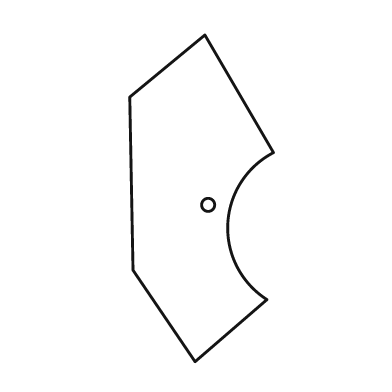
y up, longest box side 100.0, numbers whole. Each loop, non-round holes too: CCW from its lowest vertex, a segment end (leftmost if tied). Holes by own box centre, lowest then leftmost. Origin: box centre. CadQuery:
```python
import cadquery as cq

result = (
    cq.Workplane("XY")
    .moveTo(-2.0, -50.0)
    .lineTo(20.0, -31.0)
    .threePointArc((8.0, -8.0), (22.0, 14.0))
    .lineTo(1.0, 50.0)
    .lineTo(-22.0, 31.0)
    .lineTo(-21.0, -22.0)
    .close()
    .moveTo(2.0, -2.0)
    .circle(2.0)
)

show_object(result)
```